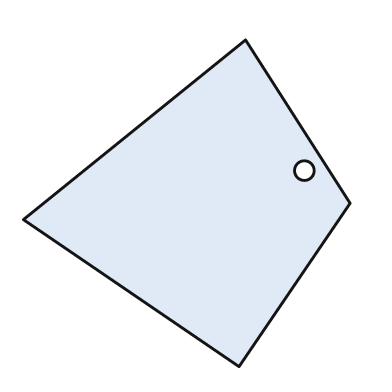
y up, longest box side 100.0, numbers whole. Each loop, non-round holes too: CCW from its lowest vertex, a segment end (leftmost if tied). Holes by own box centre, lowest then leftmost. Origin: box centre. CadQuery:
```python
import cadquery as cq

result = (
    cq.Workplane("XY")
    .moveTo(16.0, -50.0)
    .lineTo(50.0, 0.0)
    .lineTo(18.0, 50.0)
    .lineTo(-50.0, -5.0)
    .close()
    .moveTo(36.0, 10.0)
    .circle(3.0)
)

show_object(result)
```